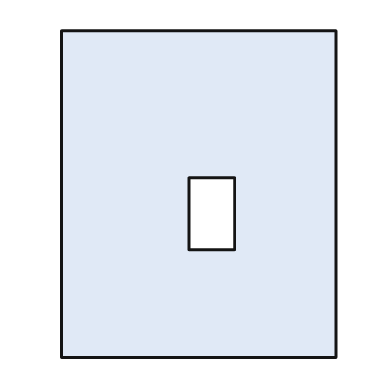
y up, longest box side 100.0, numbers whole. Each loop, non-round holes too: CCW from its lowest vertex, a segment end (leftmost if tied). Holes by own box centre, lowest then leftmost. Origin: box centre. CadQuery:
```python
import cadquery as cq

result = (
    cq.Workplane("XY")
    .moveTo(-42.0, -50.0)
    .lineTo(42.0, -50.0)
    .lineTo(42.0, 50.0)
    .lineTo(-42.0, 50.0)
    .close()
    .moveTo(-3.0, -17.0)
    .lineTo(11.0, -17.0)
    .lineTo(11.0, 5.0)
    .lineTo(-3.0, 5.0)
    .close()
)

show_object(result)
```